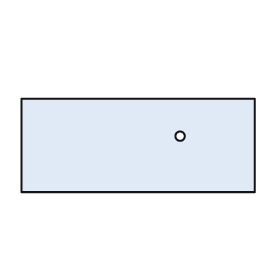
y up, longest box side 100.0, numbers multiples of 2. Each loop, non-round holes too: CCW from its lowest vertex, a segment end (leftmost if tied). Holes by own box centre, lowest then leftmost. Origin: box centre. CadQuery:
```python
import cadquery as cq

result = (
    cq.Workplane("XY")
    .moveTo(-50.0, -20.0)
    .lineTo(50.0, -20.0)
    .lineTo(50.0, 20.0)
    .lineTo(-50.0, 20.0)
    .close()
    .moveTo(18.0, 4.0)
    .circle(2.0)
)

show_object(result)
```